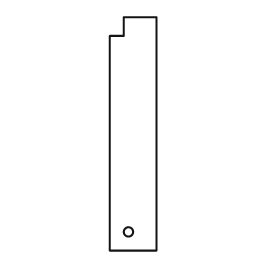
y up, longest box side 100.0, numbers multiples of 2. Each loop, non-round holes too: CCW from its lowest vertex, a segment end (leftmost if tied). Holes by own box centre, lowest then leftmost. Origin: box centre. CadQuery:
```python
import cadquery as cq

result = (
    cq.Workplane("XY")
    .moveTo(-10.0, -50.0)
    .lineTo(10.0, -50.0)
    .lineTo(10.0, 50.0)
    .lineTo(-4.0, 50.0)
    .lineTo(-4.0, 42.0)
    .lineTo(-10.0, 42.0)
    .close()
    .moveTo(-2.0, -42.0)
    .circle(2.0)
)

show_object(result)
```